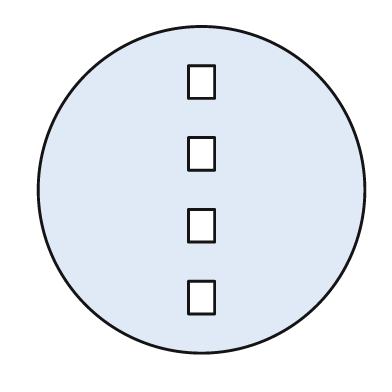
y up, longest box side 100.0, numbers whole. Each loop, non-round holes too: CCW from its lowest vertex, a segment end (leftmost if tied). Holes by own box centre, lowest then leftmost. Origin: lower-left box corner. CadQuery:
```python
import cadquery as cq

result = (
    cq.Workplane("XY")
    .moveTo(50.0, 50.0)
    .circle(50.0)
    .moveTo(46.0, 12.0)
    .lineTo(54.0, 12.0)
    .lineTo(54.0, 22.0)
    .lineTo(46.0, 22.0)
    .close()
    .moveTo(46.0, 34.0)
    .lineTo(54.0, 34.0)
    .lineTo(54.0, 44.0)
    .lineTo(46.0, 44.0)
    .close()
    .moveTo(46.0, 56.0)
    .lineTo(54.0, 56.0)
    .lineTo(54.0, 66.0)
    .lineTo(46.0, 66.0)
    .close()
    .moveTo(46.0, 78.0)
    .lineTo(54.0, 78.0)
    .lineTo(54.0, 88.0)
    .lineTo(46.0, 88.0)
    .close()
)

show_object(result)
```